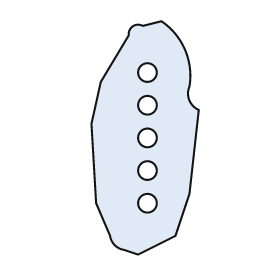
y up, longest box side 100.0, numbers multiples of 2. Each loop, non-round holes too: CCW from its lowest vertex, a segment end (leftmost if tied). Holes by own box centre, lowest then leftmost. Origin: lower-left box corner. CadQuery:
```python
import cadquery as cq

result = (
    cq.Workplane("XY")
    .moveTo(20.0, 0.0)
    .lineTo(36.0, 8.0)
    .lineTo(42.0, 26.0)
    .lineTo(46.0, 62.0)
    .threePointArc((42.0, 66.0), (42.0, 72.0))
    .threePointArc((40.0, 88.0), (30.0, 100.0))
    .lineTo(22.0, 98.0)
    .threePointArc((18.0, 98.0), (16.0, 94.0))
    .lineTo(4.0, 74.0)
    .lineTo(0.0, 56.0)
    .lineTo(2.0, 22.0)
    .lineTo(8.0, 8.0)
    .threePointArc((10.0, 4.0), (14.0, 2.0))
    .close()
    .moveTo(24.0, 22.0)
    .circle(4.0)
    .moveTo(24.0, 36.0)
    .circle(4.0)
    .moveTo(24.0, 50.0)
    .circle(4.0)
    .moveTo(24.0, 64.0)
    .circle(4.0)
    .moveTo(24.0, 78.0)
    .circle(4.0)
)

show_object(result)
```